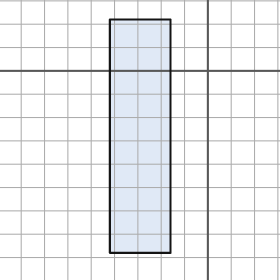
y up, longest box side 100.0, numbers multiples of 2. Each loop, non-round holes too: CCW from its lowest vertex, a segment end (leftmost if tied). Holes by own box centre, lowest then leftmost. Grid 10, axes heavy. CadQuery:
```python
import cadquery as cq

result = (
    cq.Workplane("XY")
    .moveTo(-42.0, -78.0)
    .lineTo(-16.0, -78.0)
    .lineTo(-16.0, 22.0)
    .lineTo(-42.0, 22.0)
    .close()
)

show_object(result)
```